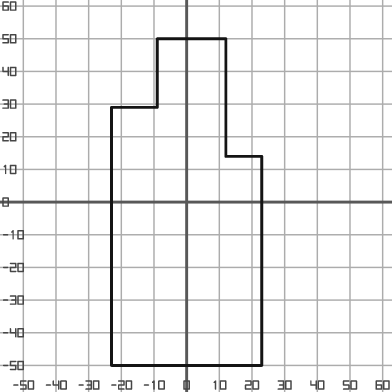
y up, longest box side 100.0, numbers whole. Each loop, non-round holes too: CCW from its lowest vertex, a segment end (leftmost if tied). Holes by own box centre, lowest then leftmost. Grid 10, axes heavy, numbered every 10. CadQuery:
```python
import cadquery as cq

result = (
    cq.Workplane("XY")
    .moveTo(-23.0, -50.0)
    .lineTo(23.0, -50.0)
    .lineTo(23.0, 14.0)
    .lineTo(12.0, 14.0)
    .lineTo(12.0, 50.0)
    .lineTo(-9.0, 50.0)
    .lineTo(-9.0, 29.0)
    .lineTo(-23.0, 29.0)
    .close()
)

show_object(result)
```